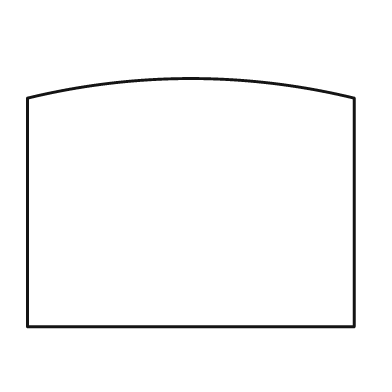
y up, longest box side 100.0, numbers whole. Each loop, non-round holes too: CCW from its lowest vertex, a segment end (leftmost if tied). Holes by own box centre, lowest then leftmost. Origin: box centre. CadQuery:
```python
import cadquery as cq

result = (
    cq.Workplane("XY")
    .moveTo(-50.0, -38.0)
    .lineTo(50.0, -38.0)
    .lineTo(50.0, 32.0)
    .threePointArc((0.0, 38.0), (-50.0, 32.0))
    .close()
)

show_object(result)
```